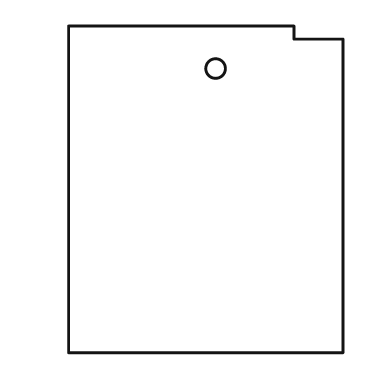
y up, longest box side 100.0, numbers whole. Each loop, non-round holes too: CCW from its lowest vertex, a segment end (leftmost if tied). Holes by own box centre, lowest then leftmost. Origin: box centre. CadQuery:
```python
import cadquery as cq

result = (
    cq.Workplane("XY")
    .moveTo(-42.0, -50.0)
    .lineTo(42.0, -50.0)
    .lineTo(42.0, 46.0)
    .lineTo(27.0, 46.0)
    .lineTo(27.0, 50.0)
    .lineTo(-42.0, 50.0)
    .close()
    .moveTo(3.0, 37.0)
    .circle(3.0)
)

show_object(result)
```